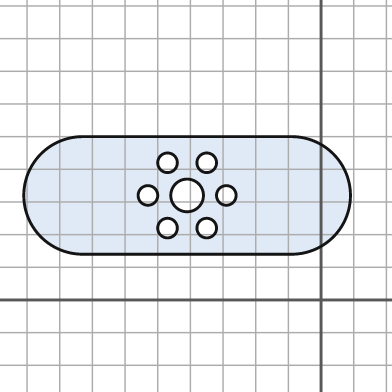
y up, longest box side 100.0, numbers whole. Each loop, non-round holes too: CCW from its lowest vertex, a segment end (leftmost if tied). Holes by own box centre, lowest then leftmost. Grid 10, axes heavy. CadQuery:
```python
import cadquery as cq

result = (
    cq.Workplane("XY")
    .moveTo(-73.0, 14.0)
    .lineTo(-9.0, 14.0)
    .threePointArc((9.0, 32.0), (-9.0, 50.0))
    .lineTo(-73.0, 50.0)
    .threePointArc((-91.0, 32.0), (-73.0, 14.0))
    .close()
    .moveTo(-47.0, 22.0)
    .circle(3.0)
    .moveTo(-35.0, 22.0)
    .circle(3.0)
    .moveTo(-53.0, 32.0)
    .circle(3.0)
    .moveTo(-41.0, 32.0)
    .circle(5.0)
    .moveTo(-29.0, 32.0)
    .circle(3.0)
    .moveTo(-47.0, 42.0)
    .circle(3.0)
    .moveTo(-35.0, 42.0)
    .circle(3.0)
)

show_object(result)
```